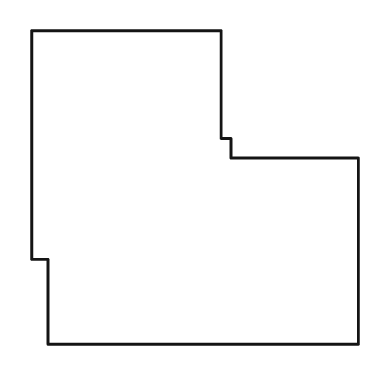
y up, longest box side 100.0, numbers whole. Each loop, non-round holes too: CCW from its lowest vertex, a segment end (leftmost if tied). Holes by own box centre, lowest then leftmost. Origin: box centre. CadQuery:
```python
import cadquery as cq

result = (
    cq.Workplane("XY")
    .moveTo(-45.0, -48.0)
    .lineTo(50.0, -48.0)
    .lineTo(50.0, 9.0)
    .lineTo(11.0, 9.0)
    .lineTo(11.0, 15.0)
    .lineTo(8.0, 15.0)
    .lineTo(8.0, 48.0)
    .lineTo(-50.0, 48.0)
    .lineTo(-50.0, -22.0)
    .lineTo(-45.0, -22.0)
    .close()
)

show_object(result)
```